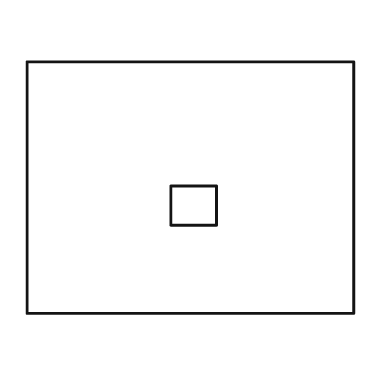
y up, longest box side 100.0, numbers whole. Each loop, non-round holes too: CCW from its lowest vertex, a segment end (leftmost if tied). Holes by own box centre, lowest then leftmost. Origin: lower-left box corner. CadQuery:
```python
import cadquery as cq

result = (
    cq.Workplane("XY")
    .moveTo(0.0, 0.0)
    .lineTo(100.0, 0.0)
    .lineTo(100.0, 77.0)
    .lineTo(0.0, 77.0)
    .close()
    .moveTo(44.0, 27.0)
    .lineTo(58.0, 27.0)
    .lineTo(58.0, 39.0)
    .lineTo(44.0, 39.0)
    .close()
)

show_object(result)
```